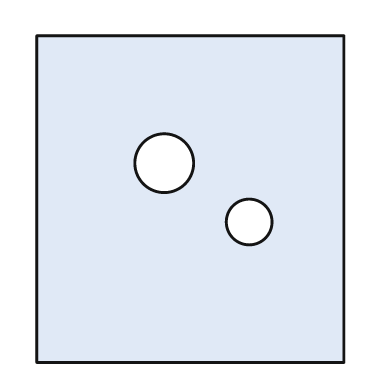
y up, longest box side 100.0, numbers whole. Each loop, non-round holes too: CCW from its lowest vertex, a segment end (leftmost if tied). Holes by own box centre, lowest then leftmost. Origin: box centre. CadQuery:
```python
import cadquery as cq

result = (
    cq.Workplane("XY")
    .moveTo(-47.0, -50.0)
    .lineTo(47.0, -50.0)
    .lineTo(47.0, 50.0)
    .lineTo(-47.0, 50.0)
    .close()
    .moveTo(18.0, -7.0)
    .circle(7.0)
    .moveTo(-8.0, 11.0)
    .circle(9.0)
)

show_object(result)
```